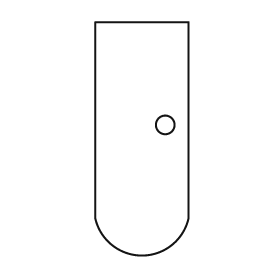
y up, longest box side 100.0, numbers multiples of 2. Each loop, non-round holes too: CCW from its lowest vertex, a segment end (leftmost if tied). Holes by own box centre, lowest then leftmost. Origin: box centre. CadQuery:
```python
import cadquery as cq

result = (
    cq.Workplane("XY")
    .moveTo(-20.0, -34.0)
    .threePointArc((0.0, -50.0), (20.0, -34.0))
    .lineTo(20.0, 50.0)
    .lineTo(-20.0, 50.0)
    .close()
    .moveTo(10.0, 6.0)
    .circle(4.0)
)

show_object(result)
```